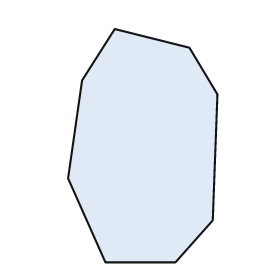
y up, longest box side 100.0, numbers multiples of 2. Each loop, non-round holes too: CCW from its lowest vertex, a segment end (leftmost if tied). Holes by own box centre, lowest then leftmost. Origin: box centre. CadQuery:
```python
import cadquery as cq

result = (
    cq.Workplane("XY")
    .moveTo(-16.0, -50.0)
    .lineTo(14.0, -50.0)
    .lineTo(30.0, -32.0)
    .lineTo(32.0, 22.0)
    .lineTo(20.0, 42.0)
    .lineTo(-12.0, 50.0)
    .lineTo(-26.0, 28.0)
    .lineTo(-32.0, -14.0)
    .close()
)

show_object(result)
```